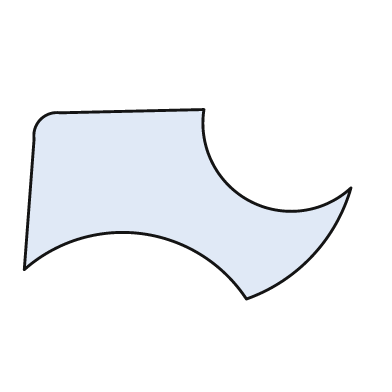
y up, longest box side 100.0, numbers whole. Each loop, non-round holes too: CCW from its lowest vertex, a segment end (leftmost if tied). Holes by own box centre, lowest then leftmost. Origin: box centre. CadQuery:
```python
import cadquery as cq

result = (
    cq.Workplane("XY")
    .moveTo(18.0, -29.0)
    .threePointArc((38.0, -16.0), (50.0, 5.0))
    .threePointArc((19.0, 1.0), (5.0, 29.0))
    .lineTo(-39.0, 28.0)
    .threePointArc((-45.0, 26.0), (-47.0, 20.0))
    .lineTo(-50.0, -20.0)
    .threePointArc((-14.0, -9.0), (18.0, -29.0))
    .close()
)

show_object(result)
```